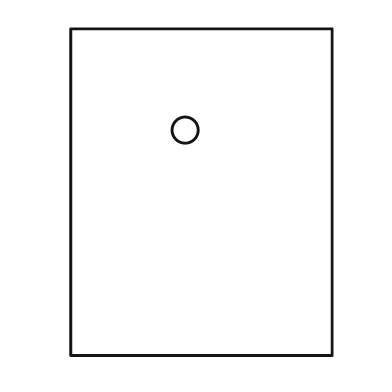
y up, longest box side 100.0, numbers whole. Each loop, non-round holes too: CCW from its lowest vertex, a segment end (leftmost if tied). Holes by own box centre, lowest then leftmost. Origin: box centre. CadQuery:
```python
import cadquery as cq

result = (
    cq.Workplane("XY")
    .moveTo(-40.0, -50.0)
    .lineTo(40.0, -50.0)
    .lineTo(40.0, 50.0)
    .lineTo(-40.0, 50.0)
    .close()
    .moveTo(-5.0, 19.0)
    .circle(4.0)
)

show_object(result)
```